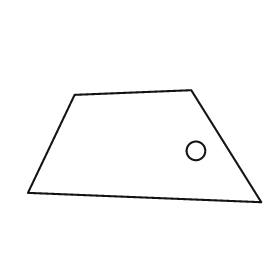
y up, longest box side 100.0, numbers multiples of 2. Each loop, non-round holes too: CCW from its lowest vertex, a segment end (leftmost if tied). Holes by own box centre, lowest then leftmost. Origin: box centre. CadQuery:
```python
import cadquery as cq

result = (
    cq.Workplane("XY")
    .moveTo(50.0, -24.0)
    .lineTo(20.0, 24.0)
    .lineTo(-30.0, 22.0)
    .lineTo(-50.0, -20.0)
    .close()
    .moveTo(22.0, -2.0)
    .circle(4.0)
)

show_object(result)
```